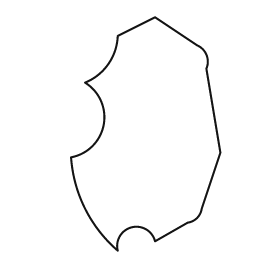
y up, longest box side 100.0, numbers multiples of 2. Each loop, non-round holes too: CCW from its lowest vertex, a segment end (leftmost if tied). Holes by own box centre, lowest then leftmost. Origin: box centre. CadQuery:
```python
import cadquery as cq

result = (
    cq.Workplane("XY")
    .moveTo(-12.0, -50.0)
    .threePointArc((-6.0, -40.0), (4.0, -46.0))
    .lineTo(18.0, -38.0)
    .threePointArc((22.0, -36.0), (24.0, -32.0))
    .lineTo(32.0, -8.0)
    .lineTo(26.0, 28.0)
    .threePointArc((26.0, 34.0), (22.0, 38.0))
    .lineTo(4.0, 50.0)
    .lineTo(-12.0, 42.0)
    .threePointArc((-16.0, 30.0), (-26.0, 22.0))
    .threePointArc((-18.0, 4.0), (-32.0, -10.0))
    .threePointArc((-26.0, -32.0), (-12.0, -50.0))
    .close()
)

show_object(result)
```